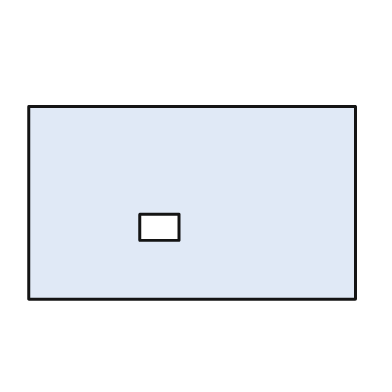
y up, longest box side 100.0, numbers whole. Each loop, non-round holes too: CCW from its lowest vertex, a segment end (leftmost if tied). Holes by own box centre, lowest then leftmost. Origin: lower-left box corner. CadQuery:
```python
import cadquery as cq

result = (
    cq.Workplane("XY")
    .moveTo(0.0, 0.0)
    .lineTo(100.0, 0.0)
    .lineTo(100.0, 59.0)
    .lineTo(0.0, 59.0)
    .close()
    .moveTo(34.0, 18.0)
    .lineTo(46.0, 18.0)
    .lineTo(46.0, 26.0)
    .lineTo(34.0, 26.0)
    .close()
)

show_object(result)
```